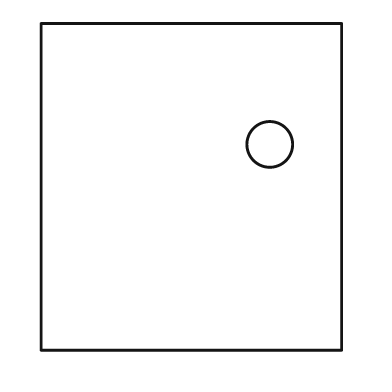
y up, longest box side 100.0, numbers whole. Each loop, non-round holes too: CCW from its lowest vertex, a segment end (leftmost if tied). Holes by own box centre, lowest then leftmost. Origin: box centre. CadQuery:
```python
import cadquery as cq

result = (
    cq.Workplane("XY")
    .moveTo(-46.0, -50.0)
    .lineTo(46.0, -50.0)
    .lineTo(46.0, 50.0)
    .lineTo(-46.0, 50.0)
    .close()
    .moveTo(24.0, 13.0)
    .circle(7.0)
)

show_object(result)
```